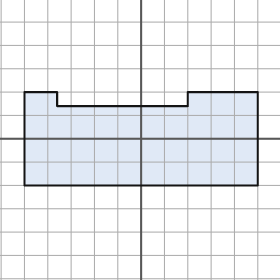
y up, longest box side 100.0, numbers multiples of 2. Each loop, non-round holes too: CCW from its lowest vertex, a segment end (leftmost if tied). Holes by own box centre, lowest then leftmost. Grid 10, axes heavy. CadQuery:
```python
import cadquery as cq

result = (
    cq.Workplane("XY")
    .moveTo(-50.0, -20.0)
    .lineTo(50.0, -20.0)
    .lineTo(50.0, 20.0)
    .lineTo(20.0, 20.0)
    .lineTo(20.0, 14.0)
    .lineTo(-36.0, 14.0)
    .lineTo(-36.0, 20.0)
    .lineTo(-50.0, 20.0)
    .close()
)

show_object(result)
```